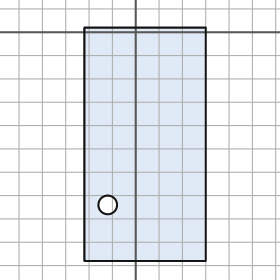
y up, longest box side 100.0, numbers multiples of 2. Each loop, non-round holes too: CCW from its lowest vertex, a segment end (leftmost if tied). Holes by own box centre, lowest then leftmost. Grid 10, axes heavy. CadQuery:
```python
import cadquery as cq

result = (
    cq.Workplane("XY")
    .moveTo(-22.0, -98.0)
    .lineTo(30.0, -98.0)
    .lineTo(30.0, 2.0)
    .lineTo(-22.0, 2.0)
    .close()
    .moveTo(-12.0, -74.0)
    .circle(4.0)
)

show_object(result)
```